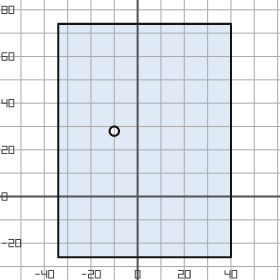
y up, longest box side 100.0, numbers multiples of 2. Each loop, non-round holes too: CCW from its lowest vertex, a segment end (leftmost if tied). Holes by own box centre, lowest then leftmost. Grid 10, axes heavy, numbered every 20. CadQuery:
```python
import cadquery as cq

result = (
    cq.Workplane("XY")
    .moveTo(-34.0, -26.0)
    .lineTo(40.0, -26.0)
    .lineTo(40.0, 74.0)
    .lineTo(-34.0, 74.0)
    .close()
    .moveTo(-10.0, 28.0)
    .circle(2.0)
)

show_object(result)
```